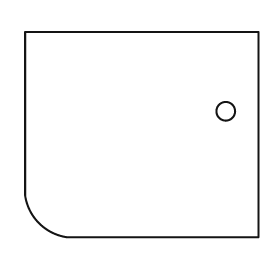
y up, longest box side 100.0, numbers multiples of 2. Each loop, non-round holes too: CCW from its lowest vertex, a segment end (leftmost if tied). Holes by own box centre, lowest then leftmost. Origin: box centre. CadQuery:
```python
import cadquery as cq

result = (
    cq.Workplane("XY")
    .moveTo(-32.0, -44.0)
    .lineTo(50.0, -44.0)
    .lineTo(50.0, 44.0)
    .lineTo(-50.0, 44.0)
    .lineTo(-50.0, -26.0)
    .threePointArc((-44.0, -38.0), (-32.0, -44.0))
    .close()
    .moveTo(36.0, 10.0)
    .circle(4.0)
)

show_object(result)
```